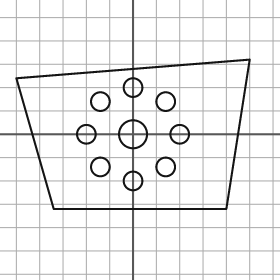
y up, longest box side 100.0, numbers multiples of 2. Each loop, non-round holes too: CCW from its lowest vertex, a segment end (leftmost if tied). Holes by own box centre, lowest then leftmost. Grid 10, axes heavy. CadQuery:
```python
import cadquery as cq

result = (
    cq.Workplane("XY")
    .moveTo(-34.0, -32.0)
    .lineTo(40.0, -32.0)
    .lineTo(50.0, 32.0)
    .lineTo(-50.0, 24.0)
    .close()
    .moveTo(0.0, -20.0)
    .circle(4.0)
    .moveTo(-14.0, -14.0)
    .circle(4.0)
    .moveTo(14.0, -14.0)
    .circle(4.0)
    .moveTo(-20.0, 0.0)
    .circle(4.0)
    .moveTo(0.0, 0.0)
    .circle(6.0)
    .moveTo(20.0, 0.0)
    .circle(4.0)
    .moveTo(-14.0, 14.0)
    .circle(4.0)
    .moveTo(14.0, 14.0)
    .circle(4.0)
    .moveTo(0.0, 20.0)
    .circle(4.0)
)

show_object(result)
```